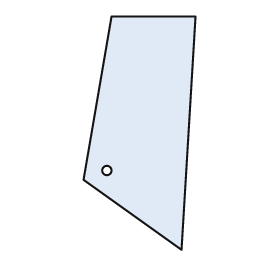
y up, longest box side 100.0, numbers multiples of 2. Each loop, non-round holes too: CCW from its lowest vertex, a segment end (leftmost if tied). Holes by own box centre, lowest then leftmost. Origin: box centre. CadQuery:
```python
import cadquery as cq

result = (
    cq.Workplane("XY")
    .moveTo(18.0, -50.0)
    .lineTo(24.0, 50.0)
    .lineTo(-12.0, 50.0)
    .lineTo(-24.0, -20.0)
    .close()
    .moveTo(-14.0, -16.0)
    .circle(2.0)
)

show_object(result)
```